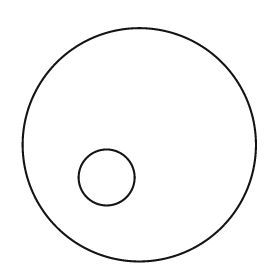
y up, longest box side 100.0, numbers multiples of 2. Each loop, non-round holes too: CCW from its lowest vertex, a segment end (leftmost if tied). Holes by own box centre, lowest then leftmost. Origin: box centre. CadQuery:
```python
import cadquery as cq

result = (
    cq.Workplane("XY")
    .moveTo(0.0, 0.0)
    .circle(50.0)
    .moveTo(-14.0, -14.0)
    .circle(12.0)
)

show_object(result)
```